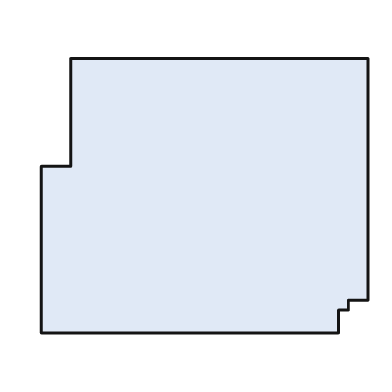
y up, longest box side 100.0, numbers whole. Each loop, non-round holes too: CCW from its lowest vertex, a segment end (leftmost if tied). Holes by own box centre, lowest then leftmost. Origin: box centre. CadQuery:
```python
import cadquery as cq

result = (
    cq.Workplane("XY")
    .moveTo(-50.0, -42.0)
    .lineTo(41.0, -42.0)
    .lineTo(41.0, -35.0)
    .lineTo(44.0, -35.0)
    .lineTo(44.0, -32.0)
    .lineTo(50.0, -32.0)
    .lineTo(50.0, 42.0)
    .lineTo(-41.0, 42.0)
    .lineTo(-41.0, 9.0)
    .lineTo(-50.0, 9.0)
    .close()
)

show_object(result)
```